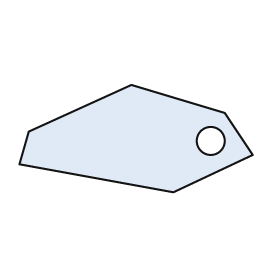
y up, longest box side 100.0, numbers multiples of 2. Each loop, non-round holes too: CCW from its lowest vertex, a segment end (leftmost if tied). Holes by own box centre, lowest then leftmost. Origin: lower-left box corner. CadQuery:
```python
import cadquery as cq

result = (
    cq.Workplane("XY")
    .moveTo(66.0, 0.0)
    .lineTo(100.0, 16.0)
    .lineTo(88.0, 34.0)
    .lineTo(48.0, 46.0)
    .lineTo(4.0, 26.0)
    .lineTo(0.0, 12.0)
    .close()
    .moveTo(82.0, 22.0)
    .circle(6.0)
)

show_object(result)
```